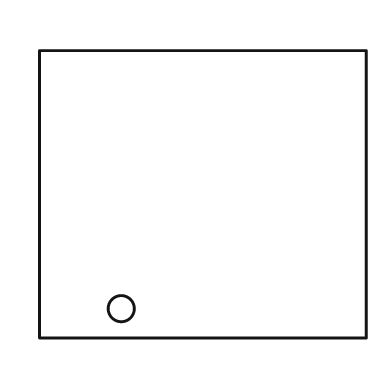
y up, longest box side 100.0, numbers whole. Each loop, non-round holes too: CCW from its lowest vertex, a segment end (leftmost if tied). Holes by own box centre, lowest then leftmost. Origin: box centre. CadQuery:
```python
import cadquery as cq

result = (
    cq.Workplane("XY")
    .moveTo(-50.0, -44.0)
    .lineTo(50.0, -44.0)
    .lineTo(50.0, 44.0)
    .lineTo(-50.0, 44.0)
    .close()
    .moveTo(-25.0, -35.0)
    .circle(4.0)
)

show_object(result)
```